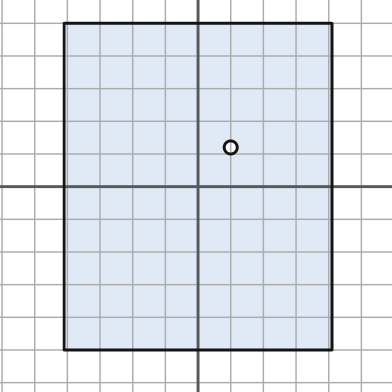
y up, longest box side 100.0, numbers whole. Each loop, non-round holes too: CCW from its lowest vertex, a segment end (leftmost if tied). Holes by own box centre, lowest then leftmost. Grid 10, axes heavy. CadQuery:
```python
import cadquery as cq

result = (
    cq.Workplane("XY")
    .moveTo(-41.0, -50.0)
    .lineTo(41.0, -50.0)
    .lineTo(41.0, 50.0)
    .lineTo(-41.0, 50.0)
    .close()
    .moveTo(10.0, 12.0)
    .circle(2.0)
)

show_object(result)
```